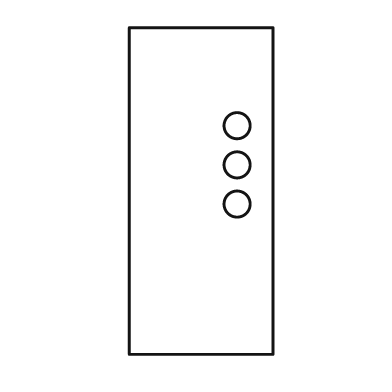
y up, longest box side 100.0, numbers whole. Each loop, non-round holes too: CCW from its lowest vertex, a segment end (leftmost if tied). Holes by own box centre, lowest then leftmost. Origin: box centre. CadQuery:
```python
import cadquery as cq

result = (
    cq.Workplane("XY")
    .moveTo(-22.0, -50.0)
    .lineTo(22.0, -50.0)
    .lineTo(22.0, 50.0)
    .lineTo(-22.0, 50.0)
    .close()
    .moveTo(11.0, -4.0)
    .circle(4.0)
    .moveTo(11.0, 8.0)
    .circle(4.0)
    .moveTo(11.0, 20.0)
    .circle(4.0)
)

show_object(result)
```